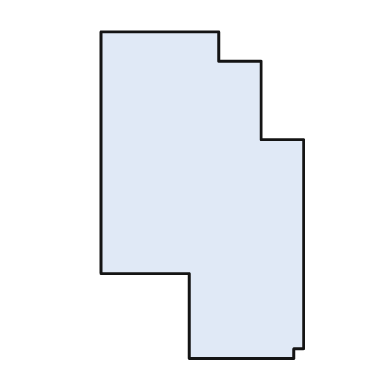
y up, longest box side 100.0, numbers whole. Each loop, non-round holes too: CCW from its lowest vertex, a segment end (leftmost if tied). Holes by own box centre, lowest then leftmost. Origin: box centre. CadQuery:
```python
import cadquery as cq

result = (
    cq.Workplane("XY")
    .moveTo(-4.0, -50.0)
    .lineTo(28.0, -50.0)
    .lineTo(28.0, -47.0)
    .lineTo(31.0, -47.0)
    .lineTo(31.0, 17.0)
    .lineTo(18.0, 17.0)
    .lineTo(18.0, 41.0)
    .lineTo(5.0, 41.0)
    .lineTo(5.0, 50.0)
    .lineTo(-31.0, 50.0)
    .lineTo(-31.0, -24.0)
    .lineTo(-4.0, -24.0)
    .close()
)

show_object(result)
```